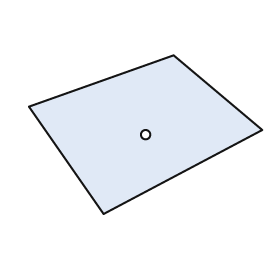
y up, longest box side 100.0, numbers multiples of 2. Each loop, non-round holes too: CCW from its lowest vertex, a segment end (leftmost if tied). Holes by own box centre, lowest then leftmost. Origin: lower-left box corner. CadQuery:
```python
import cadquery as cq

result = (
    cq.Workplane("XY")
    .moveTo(32.0, 0.0)
    .lineTo(100.0, 36.0)
    .lineTo(62.0, 68.0)
    .lineTo(0.0, 46.0)
    .close()
    .moveTo(50.0, 34.0)
    .circle(2.0)
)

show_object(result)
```